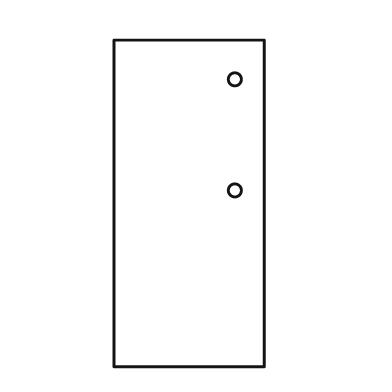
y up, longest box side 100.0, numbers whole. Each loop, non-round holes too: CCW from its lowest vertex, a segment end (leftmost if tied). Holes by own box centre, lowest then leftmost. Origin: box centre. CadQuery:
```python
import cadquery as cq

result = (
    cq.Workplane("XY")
    .moveTo(-23.0, -50.0)
    .lineTo(23.0, -50.0)
    .lineTo(23.0, 50.0)
    .lineTo(-23.0, 50.0)
    .close()
    .moveTo(14.0, 4.0)
    .circle(2.0)
    .moveTo(14.0, 38.0)
    .circle(2.0)
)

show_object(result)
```